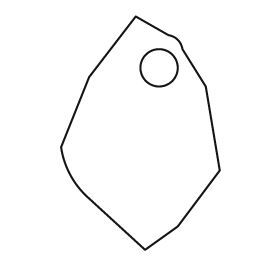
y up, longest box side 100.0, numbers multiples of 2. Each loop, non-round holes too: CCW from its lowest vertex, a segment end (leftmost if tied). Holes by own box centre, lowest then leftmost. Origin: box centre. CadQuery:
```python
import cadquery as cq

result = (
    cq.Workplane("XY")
    .moveTo(2.0, -50.0)
    .lineTo(16.0, -40.0)
    .lineTo(34.0, -16.0)
    .lineTo(28.0, 20.0)
    .lineTo(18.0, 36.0)
    .threePointArc((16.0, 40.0), (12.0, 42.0))
    .lineTo(-2.0, 50.0)
    .lineTo(-22.0, 24.0)
    .lineTo(-34.0, -6.0)
    .threePointArc((-30.0, -18.0), (-22.0, -28.0))
    .close()
    .moveTo(8.0, 28.0)
    .circle(8.0)
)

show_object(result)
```